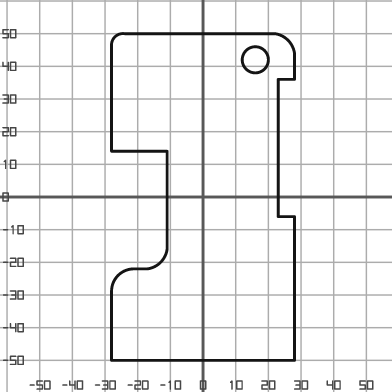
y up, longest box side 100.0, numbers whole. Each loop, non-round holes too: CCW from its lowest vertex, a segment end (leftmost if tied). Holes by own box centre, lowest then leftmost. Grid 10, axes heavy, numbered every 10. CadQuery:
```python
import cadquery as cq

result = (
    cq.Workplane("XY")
    .moveTo(-28.0, -50.0)
    .lineTo(28.0, -50.0)
    .lineTo(28.0, -6.0)
    .lineTo(23.0, -6.0)
    .lineTo(23.0, 36.0)
    .lineTo(28.0, 36.0)
    .lineTo(28.0, 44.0)
    .threePointArc((26.0, 48.0), (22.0, 50.0))
    .lineTo(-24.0, 50.0)
    .threePointArc((-27.0, 49.0), (-28.0, 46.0))
    .lineTo(-28.0, 14.0)
    .lineTo(-11.0, 14.0)
    .lineTo(-11.0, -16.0)
    .threePointArc((-13.0, -20.0), (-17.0, -22.0))
    .lineTo(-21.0, -22.0)
    .threePointArc((-26.0, -24.0), (-28.0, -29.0))
    .close()
    .moveTo(16.0, 42.0)
    .circle(4.0)
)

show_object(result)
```